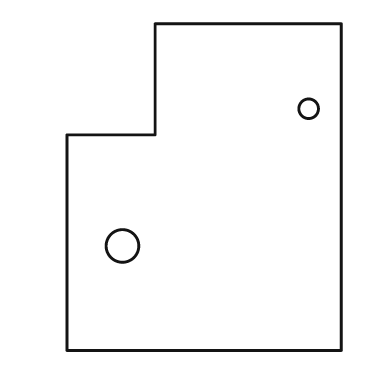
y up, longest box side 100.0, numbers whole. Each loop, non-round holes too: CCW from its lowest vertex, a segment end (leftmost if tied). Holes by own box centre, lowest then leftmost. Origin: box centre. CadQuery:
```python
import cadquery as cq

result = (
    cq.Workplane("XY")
    .moveTo(-42.0, -50.0)
    .lineTo(42.0, -50.0)
    .lineTo(42.0, 50.0)
    .lineTo(-15.0, 50.0)
    .lineTo(-15.0, 16.0)
    .lineTo(-42.0, 16.0)
    .close()
    .moveTo(-25.0, -18.0)
    .circle(5.0)
    .moveTo(32.0, 24.0)
    .circle(3.0)
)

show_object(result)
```